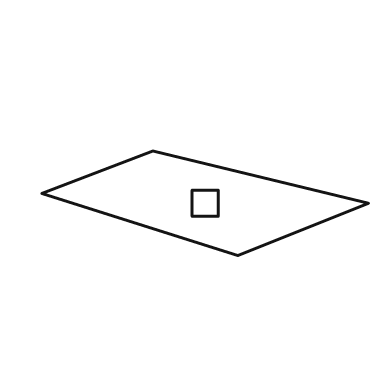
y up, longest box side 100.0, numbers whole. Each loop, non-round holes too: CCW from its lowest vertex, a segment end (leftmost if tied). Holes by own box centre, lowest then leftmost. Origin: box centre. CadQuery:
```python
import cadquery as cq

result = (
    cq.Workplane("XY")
    .moveTo(10.0, -16.0)
    .lineTo(50.0, 0.0)
    .lineTo(-16.0, 16.0)
    .lineTo(-50.0, 3.0)
    .close()
    .moveTo(-4.0, -4.0)
    .lineTo(4.0, -4.0)
    .lineTo(4.0, 4.0)
    .lineTo(-4.0, 4.0)
    .close()
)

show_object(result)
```